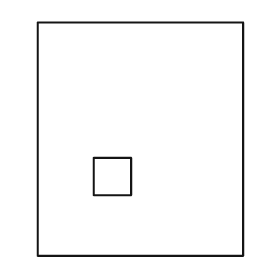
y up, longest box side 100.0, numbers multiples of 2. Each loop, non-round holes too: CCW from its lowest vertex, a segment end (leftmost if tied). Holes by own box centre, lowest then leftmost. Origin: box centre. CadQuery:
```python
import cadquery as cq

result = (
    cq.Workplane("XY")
    .moveTo(-44.0, -50.0)
    .lineTo(44.0, -50.0)
    .lineTo(44.0, 50.0)
    .lineTo(-44.0, 50.0)
    .close()
    .moveTo(-20.0, -24.0)
    .lineTo(-4.0, -24.0)
    .lineTo(-4.0, -8.0)
    .lineTo(-20.0, -8.0)
    .close()
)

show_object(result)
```